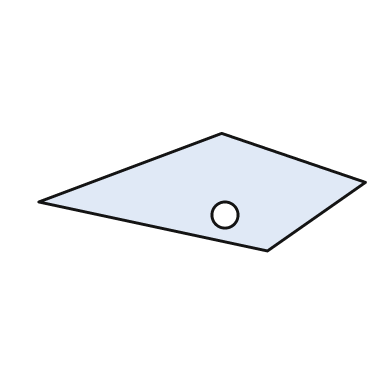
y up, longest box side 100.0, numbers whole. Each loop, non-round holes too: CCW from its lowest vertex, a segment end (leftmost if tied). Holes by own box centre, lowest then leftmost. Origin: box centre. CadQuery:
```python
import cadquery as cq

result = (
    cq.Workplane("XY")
    .moveTo(20.0, -18.0)
    .lineTo(50.0, 3.0)
    .lineTo(6.0, 18.0)
    .lineTo(-50.0, -3.0)
    .close()
    .moveTo(7.0, -7.0)
    .circle(4.0)
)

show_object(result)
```